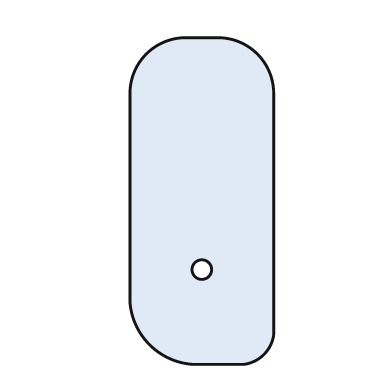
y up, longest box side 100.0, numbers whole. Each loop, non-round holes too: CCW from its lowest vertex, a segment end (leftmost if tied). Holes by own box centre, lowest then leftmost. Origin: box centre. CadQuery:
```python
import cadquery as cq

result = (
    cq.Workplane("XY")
    .moveTo(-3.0, -50.0)
    .lineTo(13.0, -50.0)
    .threePointArc((19.0, -47.0), (22.0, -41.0))
    .lineTo(22.0, 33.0)
    .threePointArc((17.0, 45.0), (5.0, 50.0))
    .lineTo(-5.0, 50.0)
    .threePointArc((-17.0, 45.0), (-22.0, 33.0))
    .lineTo(-22.0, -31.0)
    .threePointArc((-16.0, -44.0), (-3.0, -50.0))
    .close()
    .moveTo(0.0, -21.0)
    .circle(3.0)
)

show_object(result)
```